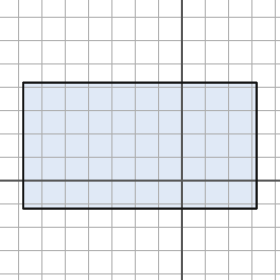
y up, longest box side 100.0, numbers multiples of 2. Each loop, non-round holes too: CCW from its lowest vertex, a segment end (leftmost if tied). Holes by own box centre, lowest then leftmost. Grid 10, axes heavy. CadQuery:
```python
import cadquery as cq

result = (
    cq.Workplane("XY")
    .moveTo(-68.0, -12.0)
    .lineTo(32.0, -12.0)
    .lineTo(32.0, 42.0)
    .lineTo(-68.0, 42.0)
    .close()
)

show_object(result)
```